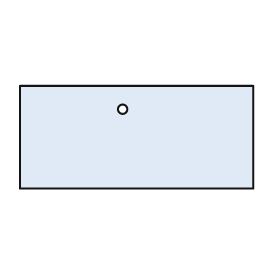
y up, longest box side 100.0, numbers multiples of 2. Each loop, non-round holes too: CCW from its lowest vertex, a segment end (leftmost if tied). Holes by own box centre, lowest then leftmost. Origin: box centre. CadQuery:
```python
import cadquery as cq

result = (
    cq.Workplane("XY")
    .moveTo(-50.0, -22.0)
    .lineTo(50.0, -22.0)
    .lineTo(50.0, 22.0)
    .lineTo(-50.0, 22.0)
    .close()
    .moveTo(-6.0, 12.0)
    .circle(2.0)
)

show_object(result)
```